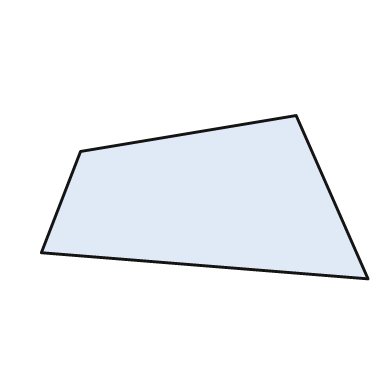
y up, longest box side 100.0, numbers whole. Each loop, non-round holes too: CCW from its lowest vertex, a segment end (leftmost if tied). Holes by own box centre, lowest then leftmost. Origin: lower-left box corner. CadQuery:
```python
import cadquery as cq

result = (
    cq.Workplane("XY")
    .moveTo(100.0, 0.0)
    .lineTo(78.0, 50.0)
    .lineTo(12.0, 39.0)
    .lineTo(0.0, 8.0)
    .close()
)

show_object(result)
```